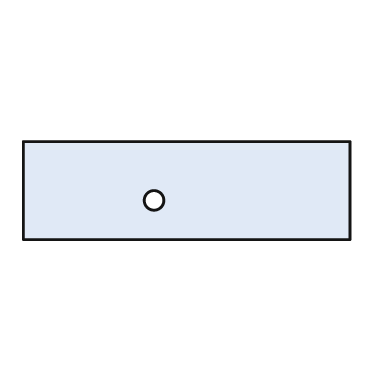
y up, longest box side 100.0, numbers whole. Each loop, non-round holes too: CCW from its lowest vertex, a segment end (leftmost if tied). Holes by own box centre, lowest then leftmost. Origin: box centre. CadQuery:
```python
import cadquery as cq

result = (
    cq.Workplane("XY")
    .moveTo(-50.0, -15.0)
    .lineTo(50.0, -15.0)
    .lineTo(50.0, 15.0)
    .lineTo(-50.0, 15.0)
    .close()
    .moveTo(-10.0, -3.0)
    .circle(3.0)
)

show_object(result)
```